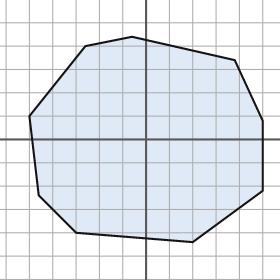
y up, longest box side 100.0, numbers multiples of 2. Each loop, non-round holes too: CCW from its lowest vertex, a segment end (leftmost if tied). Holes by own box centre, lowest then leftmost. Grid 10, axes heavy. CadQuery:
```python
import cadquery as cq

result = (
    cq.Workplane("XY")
    .moveTo(20.0, -44.0)
    .lineTo(50.0, -22.0)
    .lineTo(50.0, 8.0)
    .lineTo(38.0, 34.0)
    .lineTo(-6.0, 44.0)
    .lineTo(-26.0, 40.0)
    .lineTo(-50.0, 10.0)
    .lineTo(-46.0, -24.0)
    .lineTo(-30.0, -40.0)
    .close()
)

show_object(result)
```